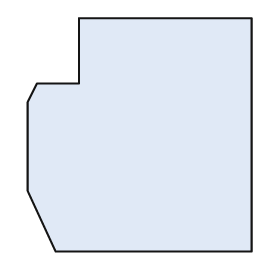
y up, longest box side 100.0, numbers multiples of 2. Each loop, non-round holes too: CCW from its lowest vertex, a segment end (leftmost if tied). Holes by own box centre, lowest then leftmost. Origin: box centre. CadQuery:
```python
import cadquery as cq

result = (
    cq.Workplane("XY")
    .moveTo(-36.0, -50.0)
    .lineTo(48.0, -50.0)
    .lineTo(48.0, 50.0)
    .lineTo(-26.0, 50.0)
    .lineTo(-26.0, 22.0)
    .lineTo(-44.0, 22.0)
    .lineTo(-48.0, 14.0)
    .lineTo(-48.0, -24.0)
    .close()
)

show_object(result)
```